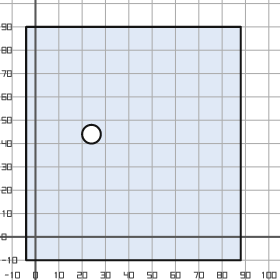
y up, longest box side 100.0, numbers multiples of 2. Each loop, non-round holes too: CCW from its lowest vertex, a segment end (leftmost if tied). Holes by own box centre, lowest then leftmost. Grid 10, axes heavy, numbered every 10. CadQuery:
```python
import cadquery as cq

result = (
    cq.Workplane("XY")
    .moveTo(-4.0, -10.0)
    .lineTo(88.0, -10.0)
    .lineTo(88.0, 90.0)
    .lineTo(-4.0, 90.0)
    .close()
    .moveTo(24.0, 44.0)
    .circle(4.0)
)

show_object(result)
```